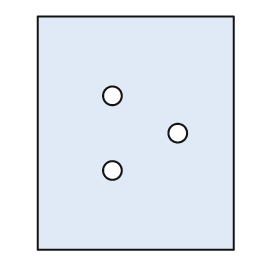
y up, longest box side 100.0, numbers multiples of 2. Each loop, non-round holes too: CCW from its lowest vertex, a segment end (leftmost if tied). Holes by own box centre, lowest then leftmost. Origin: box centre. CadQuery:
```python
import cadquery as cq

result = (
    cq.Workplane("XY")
    .moveTo(-42.0, -50.0)
    .lineTo(42.0, -50.0)
    .lineTo(42.0, 50.0)
    .lineTo(-42.0, 50.0)
    .close()
    .moveTo(-10.0, -16.0)
    .circle(4.0)
    .moveTo(18.0, 0.0)
    .circle(4.0)
    .moveTo(-10.0, 16.0)
    .circle(4.0)
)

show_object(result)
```